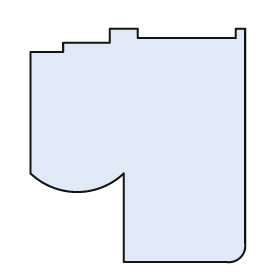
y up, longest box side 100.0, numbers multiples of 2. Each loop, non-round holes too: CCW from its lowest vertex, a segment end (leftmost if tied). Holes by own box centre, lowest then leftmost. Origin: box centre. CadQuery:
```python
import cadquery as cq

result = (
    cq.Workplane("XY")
    .moveTo(-6.0, -50.0)
    .lineTo(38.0, -50.0)
    .threePointArc((44.0, -48.0), (46.0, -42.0))
    .lineTo(46.0, 50.0)
    .lineTo(42.0, 50.0)
    .lineTo(42.0, 46.0)
    .lineTo(0.0, 46.0)
    .lineTo(0.0, 50.0)
    .lineTo(-12.0, 50.0)
    .lineTo(-12.0, 44.0)
    .lineTo(-32.0, 44.0)
    .lineTo(-32.0, 40.0)
    .lineTo(-46.0, 40.0)
    .lineTo(-46.0, -12.0)
    .threePointArc((-26.0, -20.0), (-6.0, -12.0))
    .close()
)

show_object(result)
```